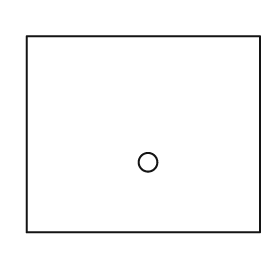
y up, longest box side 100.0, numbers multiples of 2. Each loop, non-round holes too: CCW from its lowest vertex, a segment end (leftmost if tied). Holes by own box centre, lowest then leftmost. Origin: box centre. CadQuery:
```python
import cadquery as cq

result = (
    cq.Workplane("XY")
    .moveTo(-50.0, -42.0)
    .lineTo(50.0, -42.0)
    .lineTo(50.0, 42.0)
    .lineTo(-50.0, 42.0)
    .close()
    .moveTo(2.0, -12.0)
    .circle(4.0)
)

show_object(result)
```